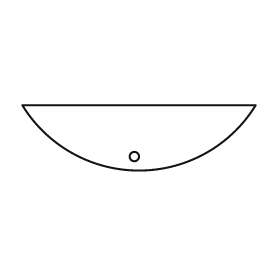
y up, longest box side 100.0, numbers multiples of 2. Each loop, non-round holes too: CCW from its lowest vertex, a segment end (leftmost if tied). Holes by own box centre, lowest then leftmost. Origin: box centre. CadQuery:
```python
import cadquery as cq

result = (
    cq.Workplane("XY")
    .moveTo(-50.0, 14.0)
    .threePointArc((0.0, -14.0), (50.0, 14.0))
    .close()
    .moveTo(-2.0, -8.0)
    .circle(2.0)
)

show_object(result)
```